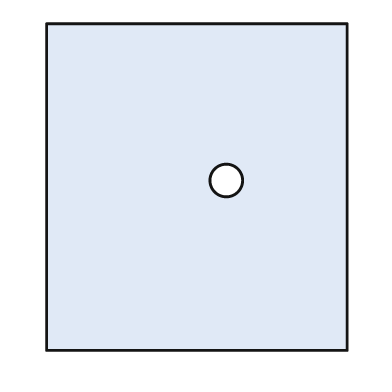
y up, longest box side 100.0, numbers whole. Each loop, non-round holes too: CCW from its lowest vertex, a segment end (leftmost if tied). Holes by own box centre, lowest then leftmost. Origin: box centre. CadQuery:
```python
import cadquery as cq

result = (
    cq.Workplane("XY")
    .moveTo(-46.0, -50.0)
    .lineTo(46.0, -50.0)
    .lineTo(46.0, 50.0)
    .lineTo(-46.0, 50.0)
    .close()
    .moveTo(9.0, 2.0)
    .circle(5.0)
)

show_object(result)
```